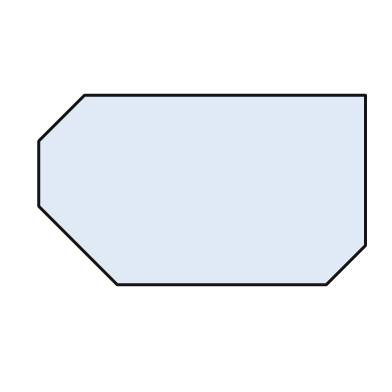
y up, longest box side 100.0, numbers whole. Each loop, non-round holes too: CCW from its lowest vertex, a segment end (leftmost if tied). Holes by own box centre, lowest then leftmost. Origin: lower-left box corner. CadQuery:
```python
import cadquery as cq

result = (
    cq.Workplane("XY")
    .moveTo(24.0, 0.0)
    .lineTo(88.0, 0.0)
    .lineTo(100.0, 12.0)
    .lineTo(100.0, 58.0)
    .lineTo(14.0, 58.0)
    .lineTo(0.0, 44.0)
    .lineTo(0.0, 24.0)
    .close()
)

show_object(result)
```